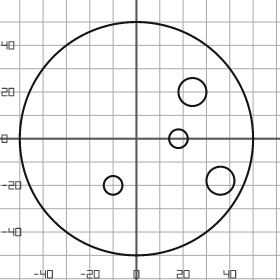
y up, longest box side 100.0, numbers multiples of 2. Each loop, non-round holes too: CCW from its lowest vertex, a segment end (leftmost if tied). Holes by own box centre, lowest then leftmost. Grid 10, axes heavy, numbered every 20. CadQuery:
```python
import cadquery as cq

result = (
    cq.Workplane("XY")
    .moveTo(0.0, 0.0)
    .circle(50.0)
    .moveTo(-10.0, -20.0)
    .circle(4.0)
    .moveTo(36.0, -18.0)
    .circle(6.0)
    .moveTo(18.0, 0.0)
    .circle(4.0)
    .moveTo(24.0, 20.0)
    .circle(6.0)
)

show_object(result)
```